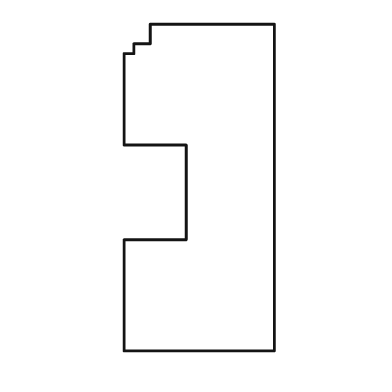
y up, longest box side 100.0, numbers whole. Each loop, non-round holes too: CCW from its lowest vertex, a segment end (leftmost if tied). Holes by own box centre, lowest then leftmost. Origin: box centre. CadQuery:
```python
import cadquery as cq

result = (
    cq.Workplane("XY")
    .moveTo(-23.0, -50.0)
    .lineTo(23.0, -50.0)
    .lineTo(23.0, 50.0)
    .lineTo(-15.0, 50.0)
    .lineTo(-15.0, 44.0)
    .lineTo(-20.0, 44.0)
    .lineTo(-20.0, 41.0)
    .lineTo(-23.0, 41.0)
    .lineTo(-23.0, 13.0)
    .lineTo(-4.0, 13.0)
    .lineTo(-4.0, -16.0)
    .lineTo(-23.0, -16.0)
    .close()
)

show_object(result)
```